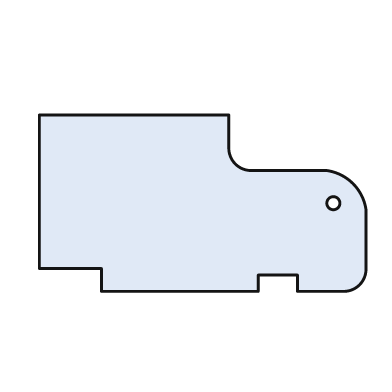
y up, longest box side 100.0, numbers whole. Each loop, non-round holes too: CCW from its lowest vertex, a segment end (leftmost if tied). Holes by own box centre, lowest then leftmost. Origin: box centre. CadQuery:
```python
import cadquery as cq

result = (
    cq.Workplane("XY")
    .moveTo(-31.0, -27.0)
    .lineTo(17.0, -27.0)
    .lineTo(17.0, -22.0)
    .lineTo(29.0, -22.0)
    .lineTo(29.0, -27.0)
    .lineTo(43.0, -27.0)
    .threePointArc((48.0, -25.0), (50.0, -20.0))
    .lineTo(50.0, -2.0)
    .threePointArc((46.0, 6.0), (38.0, 10.0))
    .lineTo(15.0, 10.0)
    .threePointArc((10.0, 12.0), (8.0, 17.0))
    .lineTo(8.0, 27.0)
    .lineTo(-50.0, 27.0)
    .lineTo(-50.0, -20.0)
    .lineTo(-31.0, -20.0)
    .close()
    .moveTo(40.0, 0.0)
    .circle(2.0)
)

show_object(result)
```